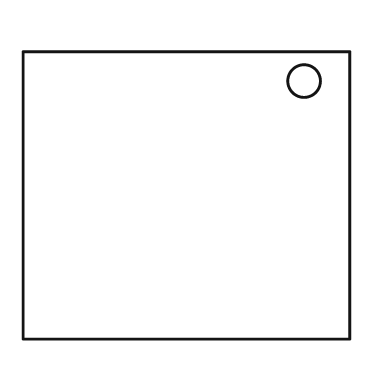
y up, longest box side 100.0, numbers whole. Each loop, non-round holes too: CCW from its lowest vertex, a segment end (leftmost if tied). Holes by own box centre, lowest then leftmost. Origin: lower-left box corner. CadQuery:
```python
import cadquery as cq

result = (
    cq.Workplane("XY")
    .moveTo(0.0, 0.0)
    .lineTo(100.0, 0.0)
    .lineTo(100.0, 88.0)
    .lineTo(0.0, 88.0)
    .close()
    .moveTo(86.0, 79.0)
    .circle(5.0)
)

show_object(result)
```